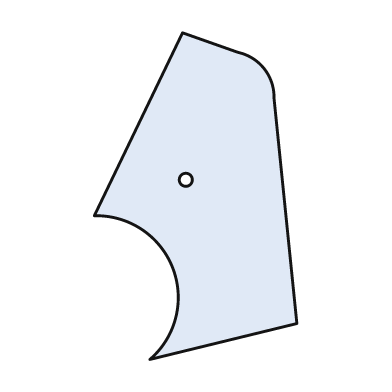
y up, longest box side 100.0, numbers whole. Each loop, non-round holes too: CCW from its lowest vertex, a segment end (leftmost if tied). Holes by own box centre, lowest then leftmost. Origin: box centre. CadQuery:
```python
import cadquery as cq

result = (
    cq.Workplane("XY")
    .moveTo(-14.0, -50.0)
    .lineTo(31.0, -39.0)
    .lineTo(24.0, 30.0)
    .threePointArc((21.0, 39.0), (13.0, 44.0))
    .lineTo(-4.0, 50.0)
    .lineTo(-31.0, -6.0)
    .threePointArc((-7.0, -22.0), (-14.0, -50.0))
    .close()
    .moveTo(-3.0, 5.0)
    .circle(2.0)
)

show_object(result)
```